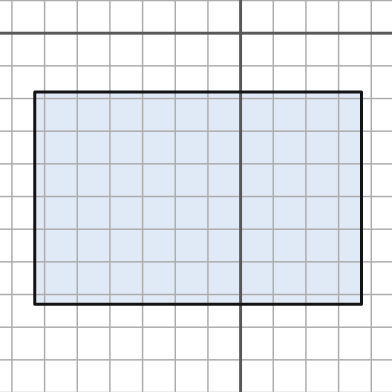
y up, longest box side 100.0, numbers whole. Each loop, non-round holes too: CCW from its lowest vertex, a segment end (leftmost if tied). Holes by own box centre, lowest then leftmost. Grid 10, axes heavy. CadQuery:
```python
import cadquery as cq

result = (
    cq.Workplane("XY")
    .moveTo(-63.0, -83.0)
    .lineTo(37.0, -83.0)
    .lineTo(37.0, -18.0)
    .lineTo(-63.0, -18.0)
    .close()
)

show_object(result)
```